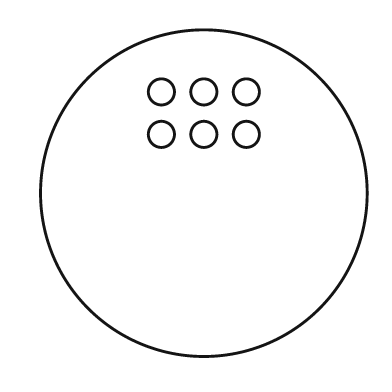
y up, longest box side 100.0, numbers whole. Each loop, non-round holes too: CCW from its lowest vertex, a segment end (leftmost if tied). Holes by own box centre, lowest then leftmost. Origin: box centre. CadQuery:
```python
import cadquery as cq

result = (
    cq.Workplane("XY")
    .moveTo(0.0, 0.0)
    .circle(50.0)
    .moveTo(-13.0, 18.0)
    .circle(4.0)
    .moveTo(0.0, 18.0)
    .circle(4.0)
    .moveTo(13.0, 18.0)
    .circle(4.0)
    .moveTo(-13.0, 31.0)
    .circle(4.0)
    .moveTo(0.0, 31.0)
    .circle(4.0)
    .moveTo(13.0, 31.0)
    .circle(4.0)
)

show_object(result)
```